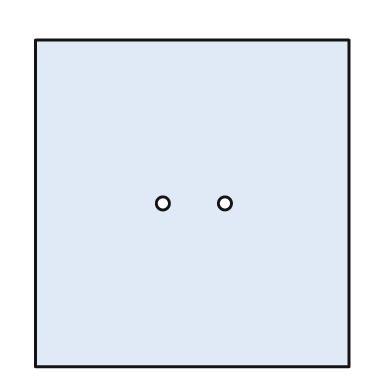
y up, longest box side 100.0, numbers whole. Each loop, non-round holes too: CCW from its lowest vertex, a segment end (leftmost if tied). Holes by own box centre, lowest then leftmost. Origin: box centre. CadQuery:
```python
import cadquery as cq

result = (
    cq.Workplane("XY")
    .moveTo(-48.0, -50.0)
    .lineTo(48.0, -50.0)
    .lineTo(48.0, 50.0)
    .lineTo(-48.0, 50.0)
    .close()
    .moveTo(-9.0, 0.0)
    .circle(2.0)
    .moveTo(10.0, 0.0)
    .circle(2.0)
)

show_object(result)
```